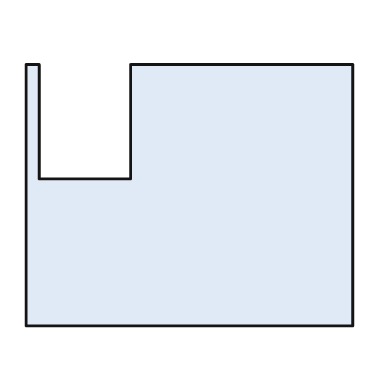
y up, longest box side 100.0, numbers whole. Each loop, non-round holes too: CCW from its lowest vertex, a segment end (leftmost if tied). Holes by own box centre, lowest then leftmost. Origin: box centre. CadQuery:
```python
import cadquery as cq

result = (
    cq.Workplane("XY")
    .moveTo(-50.0, -40.0)
    .lineTo(50.0, -40.0)
    .lineTo(50.0, 40.0)
    .lineTo(-18.0, 40.0)
    .lineTo(-18.0, 5.0)
    .lineTo(-46.0, 5.0)
    .lineTo(-46.0, 40.0)
    .lineTo(-50.0, 40.0)
    .close()
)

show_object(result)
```